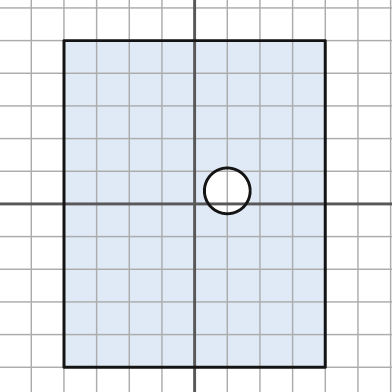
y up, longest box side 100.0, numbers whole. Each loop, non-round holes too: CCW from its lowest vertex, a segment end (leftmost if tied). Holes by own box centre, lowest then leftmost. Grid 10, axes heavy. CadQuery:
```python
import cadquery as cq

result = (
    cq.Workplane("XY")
    .moveTo(-40.0, -50.0)
    .lineTo(40.0, -50.0)
    .lineTo(40.0, 50.0)
    .lineTo(-40.0, 50.0)
    .close()
    .moveTo(10.0, 4.0)
    .circle(7.0)
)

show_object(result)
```